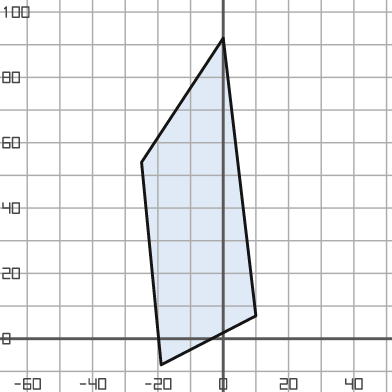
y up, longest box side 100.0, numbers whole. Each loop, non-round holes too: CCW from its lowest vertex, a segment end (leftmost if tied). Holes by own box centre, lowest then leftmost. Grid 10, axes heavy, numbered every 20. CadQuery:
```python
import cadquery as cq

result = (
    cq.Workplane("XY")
    .moveTo(-19.0, -8.0)
    .lineTo(10.0, 7.0)
    .lineTo(0.0, 92.0)
    .lineTo(-25.0, 54.0)
    .close()
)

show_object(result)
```